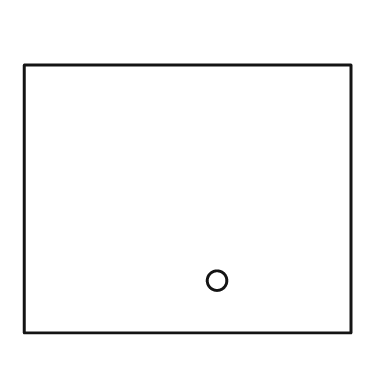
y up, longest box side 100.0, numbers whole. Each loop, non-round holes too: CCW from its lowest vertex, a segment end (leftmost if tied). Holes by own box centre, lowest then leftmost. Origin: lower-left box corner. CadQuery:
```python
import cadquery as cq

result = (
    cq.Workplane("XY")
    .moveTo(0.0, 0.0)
    .lineTo(100.0, 0.0)
    .lineTo(100.0, 82.0)
    .lineTo(0.0, 82.0)
    .close()
    .moveTo(59.0, 16.0)
    .circle(3.0)
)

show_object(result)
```